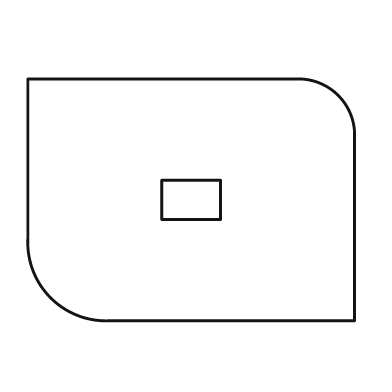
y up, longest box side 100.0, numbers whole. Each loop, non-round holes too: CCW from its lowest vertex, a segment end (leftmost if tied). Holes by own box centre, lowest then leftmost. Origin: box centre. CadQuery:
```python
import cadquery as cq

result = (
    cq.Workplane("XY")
    .moveTo(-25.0, -37.0)
    .lineTo(50.0, -37.0)
    .lineTo(50.0, 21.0)
    .threePointArc((45.0, 32.0), (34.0, 37.0))
    .lineTo(-50.0, 37.0)
    .lineTo(-50.0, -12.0)
    .threePointArc((-43.0, -30.0), (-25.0, -37.0))
    .close()
    .moveTo(-9.0, -6.0)
    .lineTo(9.0, -6.0)
    .lineTo(9.0, 6.0)
    .lineTo(-9.0, 6.0)
    .close()
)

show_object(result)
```